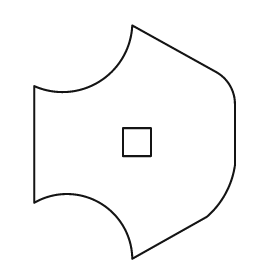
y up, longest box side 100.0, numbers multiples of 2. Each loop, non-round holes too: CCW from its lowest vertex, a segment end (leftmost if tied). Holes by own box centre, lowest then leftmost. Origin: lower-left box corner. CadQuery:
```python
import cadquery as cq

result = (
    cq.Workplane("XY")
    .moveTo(42.0, 0.0)
    .lineTo(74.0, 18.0)
    .threePointArc((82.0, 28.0), (86.0, 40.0))
    .lineTo(86.0, 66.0)
    .threePointArc((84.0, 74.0), (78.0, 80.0))
    .lineTo(42.0, 100.0)
    .threePointArc((28.0, 76.0), (0.0, 74.0))
    .lineTo(0.0, 24.0)
    .threePointArc((28.0, 24.0), (42.0, 0.0))
    .close()
    .moveTo(38.0, 44.0)
    .lineTo(50.0, 44.0)
    .lineTo(50.0, 56.0)
    .lineTo(38.0, 56.0)
    .close()
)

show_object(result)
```